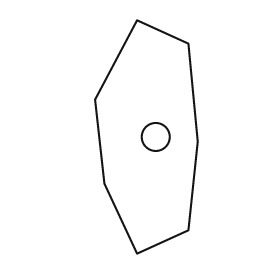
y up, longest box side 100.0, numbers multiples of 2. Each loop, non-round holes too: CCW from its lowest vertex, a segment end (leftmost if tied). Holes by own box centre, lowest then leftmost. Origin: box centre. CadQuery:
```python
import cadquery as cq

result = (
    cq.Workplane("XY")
    .moveTo(-4.0, -50.0)
    .lineTo(18.0, -40.0)
    .lineTo(22.0, -2.0)
    .lineTo(18.0, 40.0)
    .lineTo(-4.0, 50.0)
    .lineTo(-22.0, 16.0)
    .lineTo(-18.0, -20.0)
    .close()
    .moveTo(4.0, 0.0)
    .circle(6.0)
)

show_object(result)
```